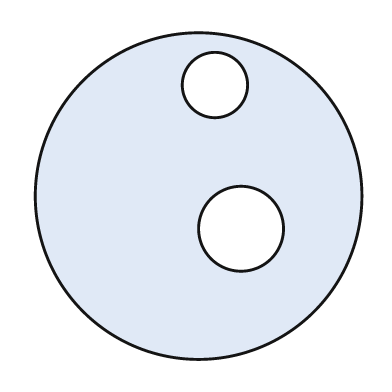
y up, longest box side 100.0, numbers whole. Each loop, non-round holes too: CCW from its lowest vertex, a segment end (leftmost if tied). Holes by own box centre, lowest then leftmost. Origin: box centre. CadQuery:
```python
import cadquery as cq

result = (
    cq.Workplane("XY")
    .moveTo(0.0, 0.0)
    .circle(50.0)
    .moveTo(13.0, -10.0)
    .circle(13.0)
    .moveTo(5.0, 34.0)
    .circle(10.0)
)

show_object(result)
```